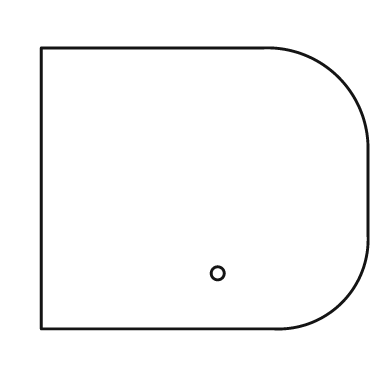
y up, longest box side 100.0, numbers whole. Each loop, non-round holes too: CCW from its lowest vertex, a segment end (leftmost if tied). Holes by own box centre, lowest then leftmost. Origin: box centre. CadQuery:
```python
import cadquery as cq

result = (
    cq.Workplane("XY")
    .moveTo(-50.0, -43.0)
    .lineTo(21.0, -43.0)
    .threePointArc((42.0, -35.0), (50.0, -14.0))
    .lineTo(50.0, 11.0)
    .threePointArc((41.0, 34.0), (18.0, 43.0))
    .lineTo(-50.0, 43.0)
    .close()
    .moveTo(4.0, -26.0)
    .circle(2.0)
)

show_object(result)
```